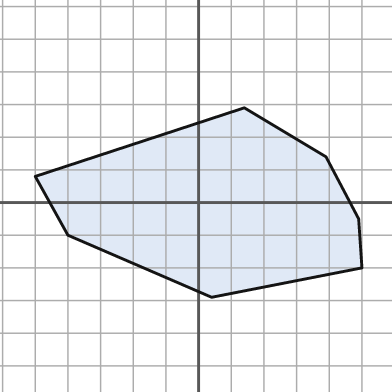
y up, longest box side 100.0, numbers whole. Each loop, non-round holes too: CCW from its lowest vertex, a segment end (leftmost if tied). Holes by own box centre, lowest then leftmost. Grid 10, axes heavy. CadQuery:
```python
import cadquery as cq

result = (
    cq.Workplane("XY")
    .moveTo(4.0, -29.0)
    .lineTo(50.0, -20.0)
    .lineTo(49.0, -5.0)
    .lineTo(39.0, 14.0)
    .lineTo(14.0, 29.0)
    .lineTo(-50.0, 8.0)
    .lineTo(-40.0, -10.0)
    .close()
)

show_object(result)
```